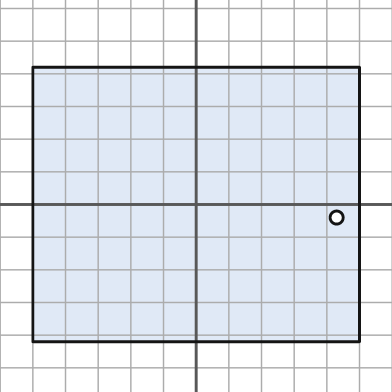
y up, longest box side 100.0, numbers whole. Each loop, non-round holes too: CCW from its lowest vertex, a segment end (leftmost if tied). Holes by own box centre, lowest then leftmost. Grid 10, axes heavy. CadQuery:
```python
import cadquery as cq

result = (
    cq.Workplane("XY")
    .moveTo(-50.0, -42.0)
    .lineTo(50.0, -42.0)
    .lineTo(50.0, 42.0)
    .lineTo(-50.0, 42.0)
    .close()
    .moveTo(43.0, -4.0)
    .circle(2.0)
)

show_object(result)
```